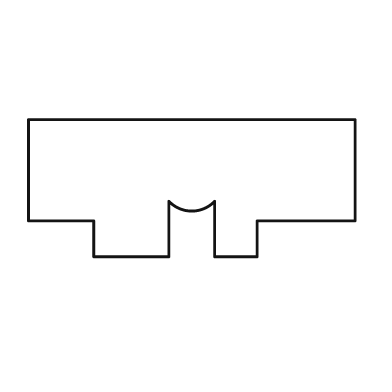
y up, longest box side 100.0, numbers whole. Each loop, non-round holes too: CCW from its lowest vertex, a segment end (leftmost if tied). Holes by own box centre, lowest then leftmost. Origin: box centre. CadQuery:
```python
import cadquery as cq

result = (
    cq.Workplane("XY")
    .moveTo(-30.0, -21.0)
    .lineTo(-7.0, -21.0)
    .lineTo(-7.0, -4.0)
    .threePointArc((0.0, -7.0), (7.0, -4.0))
    .lineTo(7.0, -21.0)
    .lineTo(20.0, -21.0)
    .lineTo(20.0, -10.0)
    .lineTo(50.0, -10.0)
    .lineTo(50.0, 21.0)
    .lineTo(-50.0, 21.0)
    .lineTo(-50.0, -10.0)
    .lineTo(-30.0, -10.0)
    .close()
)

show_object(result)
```